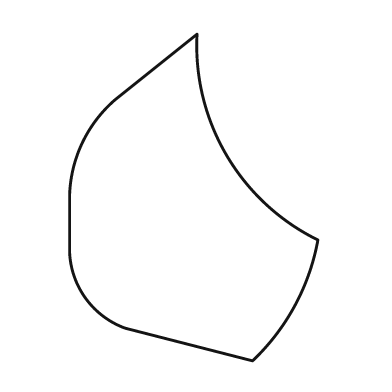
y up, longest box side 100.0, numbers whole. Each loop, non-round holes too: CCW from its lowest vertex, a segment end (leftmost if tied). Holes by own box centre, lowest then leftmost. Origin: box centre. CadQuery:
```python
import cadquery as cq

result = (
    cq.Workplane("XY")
    .moveTo(18.0, -50.0)
    .threePointArc((31.0, -33.0), (38.0, -13.0))
    .threePointArc((10.0, 13.0), (1.0, 50.0))
    .lineTo(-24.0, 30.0)
    .threePointArc((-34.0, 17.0), (-38.0, 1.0))
    .lineTo(-38.0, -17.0)
    .threePointArc((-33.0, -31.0), (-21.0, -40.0))
    .close()
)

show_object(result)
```